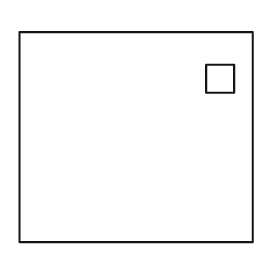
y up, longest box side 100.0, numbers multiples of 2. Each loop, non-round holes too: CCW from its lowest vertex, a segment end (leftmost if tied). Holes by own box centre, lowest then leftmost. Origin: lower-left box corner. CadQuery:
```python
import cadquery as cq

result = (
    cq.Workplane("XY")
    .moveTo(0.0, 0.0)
    .lineTo(100.0, 0.0)
    .lineTo(100.0, 90.0)
    .lineTo(0.0, 90.0)
    .close()
    .moveTo(80.0, 64.0)
    .lineTo(92.0, 64.0)
    .lineTo(92.0, 76.0)
    .lineTo(80.0, 76.0)
    .close()
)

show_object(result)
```